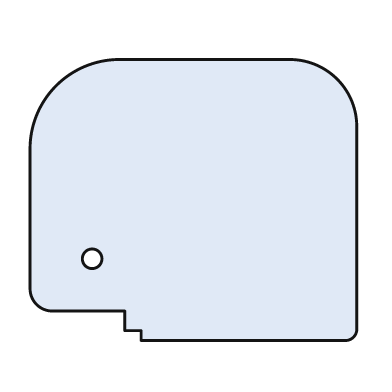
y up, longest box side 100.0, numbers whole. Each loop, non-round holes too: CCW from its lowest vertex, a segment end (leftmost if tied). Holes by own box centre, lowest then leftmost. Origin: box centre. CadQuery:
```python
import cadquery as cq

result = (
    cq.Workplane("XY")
    .moveTo(-16.0, -43.0)
    .lineTo(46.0, -43.0)
    .threePointArc((49.0, -42.0), (50.0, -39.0))
    .lineTo(50.0, 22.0)
    .threePointArc((44.0, 37.0), (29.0, 43.0))
    .lineTo(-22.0, 43.0)
    .threePointArc((-42.0, 35.0), (-50.0, 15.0))
    .lineTo(-50.0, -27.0)
    .threePointArc((-48.0, -32.0), (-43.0, -34.0))
    .lineTo(-21.0, -34.0)
    .lineTo(-21.0, -40.0)
    .lineTo(-16.0, -40.0)
    .close()
    .moveTo(-31.0, -18.0)
    .circle(3.0)
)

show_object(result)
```